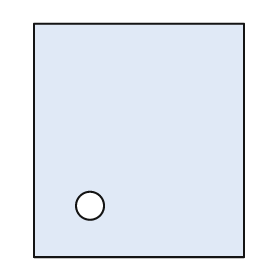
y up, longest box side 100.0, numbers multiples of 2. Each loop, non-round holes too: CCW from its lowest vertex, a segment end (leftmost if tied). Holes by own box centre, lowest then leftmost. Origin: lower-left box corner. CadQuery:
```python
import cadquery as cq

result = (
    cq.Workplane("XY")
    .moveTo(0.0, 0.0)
    .lineTo(90.0, 0.0)
    .lineTo(90.0, 100.0)
    .lineTo(0.0, 100.0)
    .close()
    .moveTo(24.0, 22.0)
    .circle(6.0)
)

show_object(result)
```